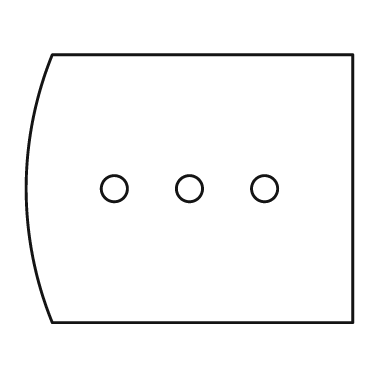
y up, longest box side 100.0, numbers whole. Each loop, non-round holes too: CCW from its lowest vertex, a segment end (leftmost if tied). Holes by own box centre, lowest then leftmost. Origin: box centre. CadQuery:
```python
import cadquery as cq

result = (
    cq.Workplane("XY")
    .moveTo(-42.0, -41.0)
    .lineTo(50.0, -41.0)
    .lineTo(50.0, 41.0)
    .lineTo(-42.0, 41.0)
    .threePointArc((-50.0, 0.0), (-42.0, -41.0))
    .close()
    .moveTo(-23.0, 0.0)
    .circle(4.0)
    .moveTo(0.0, 0.0)
    .circle(4.0)
    .moveTo(23.0, 0.0)
    .circle(4.0)
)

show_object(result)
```